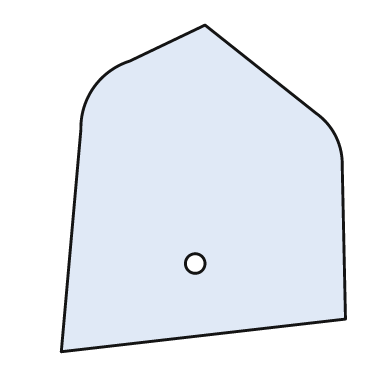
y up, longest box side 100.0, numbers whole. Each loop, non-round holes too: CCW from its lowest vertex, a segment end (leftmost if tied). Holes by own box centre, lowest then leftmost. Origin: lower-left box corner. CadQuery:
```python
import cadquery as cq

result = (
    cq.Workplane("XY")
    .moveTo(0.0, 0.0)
    .lineTo(87.0, 10.0)
    .lineTo(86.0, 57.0)
    .threePointArc((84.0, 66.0), (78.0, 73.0))
    .lineTo(44.0, 100.0)
    .lineTo(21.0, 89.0)
    .threePointArc((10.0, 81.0), (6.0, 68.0))
    .close()
    .moveTo(41.0, 27.0)
    .circle(3.0)
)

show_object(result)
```